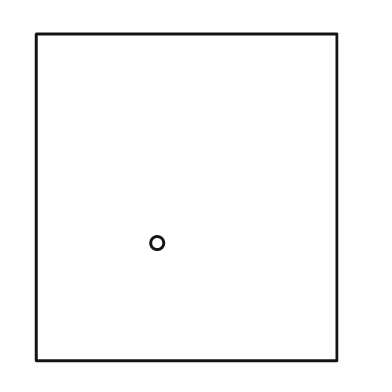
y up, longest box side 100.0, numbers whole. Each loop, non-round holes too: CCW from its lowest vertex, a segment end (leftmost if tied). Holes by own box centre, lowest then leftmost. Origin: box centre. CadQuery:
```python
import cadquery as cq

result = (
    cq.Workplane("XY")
    .moveTo(-46.0, -50.0)
    .lineTo(46.0, -50.0)
    .lineTo(46.0, 50.0)
    .lineTo(-46.0, 50.0)
    .close()
    .moveTo(-9.0, -14.0)
    .circle(2.0)
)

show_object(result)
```